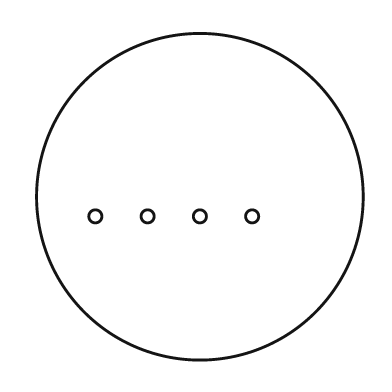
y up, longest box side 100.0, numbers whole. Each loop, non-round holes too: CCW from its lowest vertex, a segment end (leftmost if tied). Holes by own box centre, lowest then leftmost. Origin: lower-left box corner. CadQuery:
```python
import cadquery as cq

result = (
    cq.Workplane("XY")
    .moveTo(50.0, 50.0)
    .circle(50.0)
    .moveTo(18.0, 44.0)
    .circle(2.0)
    .moveTo(34.0, 44.0)
    .circle(2.0)
    .moveTo(50.0, 44.0)
    .circle(2.0)
    .moveTo(66.0, 44.0)
    .circle(2.0)
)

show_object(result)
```